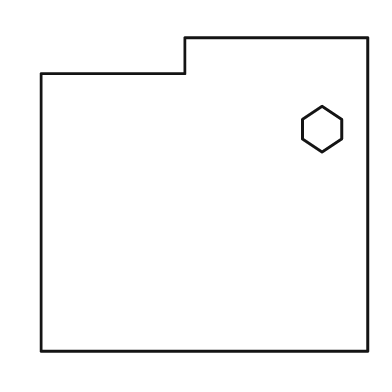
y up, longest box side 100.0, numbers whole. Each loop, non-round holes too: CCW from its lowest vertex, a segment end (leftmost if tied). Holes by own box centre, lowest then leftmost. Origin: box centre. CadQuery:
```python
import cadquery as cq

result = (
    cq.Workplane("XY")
    .moveTo(-50.0, -48.0)
    .lineTo(50.0, -48.0)
    .lineTo(50.0, 48.0)
    .lineTo(-6.0, 48.0)
    .lineTo(-6.0, 37.0)
    .lineTo(-50.0, 37.0)
    .close()
    .moveTo(36.0, 13.0)
    .lineTo(42.0, 17.0)
    .lineTo(42.0, 23.0)
    .lineTo(36.0, 27.0)
    .lineTo(30.0, 23.0)
    .lineTo(30.0, 17.0)
    .close()
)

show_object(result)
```